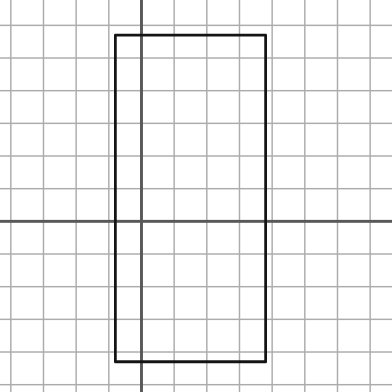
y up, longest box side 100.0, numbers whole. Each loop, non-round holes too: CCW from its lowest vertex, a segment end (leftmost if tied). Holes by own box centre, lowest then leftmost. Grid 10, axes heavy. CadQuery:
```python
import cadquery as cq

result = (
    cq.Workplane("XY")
    .moveTo(-8.0, -43.0)
    .lineTo(38.0, -43.0)
    .lineTo(38.0, 57.0)
    .lineTo(-8.0, 57.0)
    .close()
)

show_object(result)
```